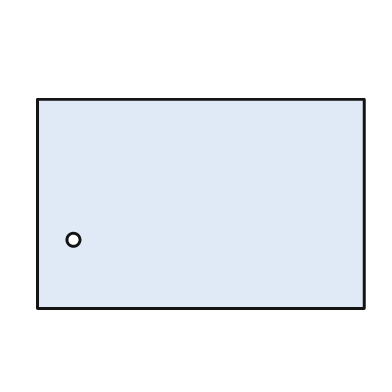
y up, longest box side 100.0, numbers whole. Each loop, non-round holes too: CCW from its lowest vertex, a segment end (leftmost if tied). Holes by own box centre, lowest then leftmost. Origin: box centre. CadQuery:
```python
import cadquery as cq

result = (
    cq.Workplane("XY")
    .moveTo(-50.0, -32.0)
    .lineTo(50.0, -32.0)
    .lineTo(50.0, 32.0)
    .lineTo(-50.0, 32.0)
    .close()
    .moveTo(-39.0, -11.0)
    .circle(2.0)
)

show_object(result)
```